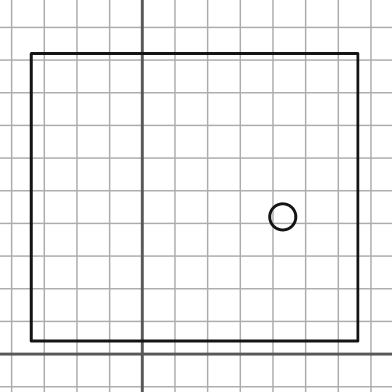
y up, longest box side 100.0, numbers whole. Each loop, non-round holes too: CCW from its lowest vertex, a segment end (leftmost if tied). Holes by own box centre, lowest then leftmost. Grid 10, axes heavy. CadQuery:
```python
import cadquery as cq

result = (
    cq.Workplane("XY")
    .moveTo(-34.0, 4.0)
    .lineTo(66.0, 4.0)
    .lineTo(66.0, 92.0)
    .lineTo(-34.0, 92.0)
    .close()
    .moveTo(43.0, 42.0)
    .circle(4.0)
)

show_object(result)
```